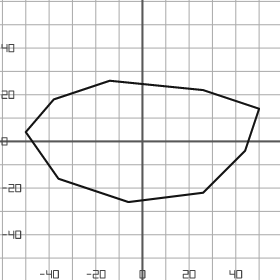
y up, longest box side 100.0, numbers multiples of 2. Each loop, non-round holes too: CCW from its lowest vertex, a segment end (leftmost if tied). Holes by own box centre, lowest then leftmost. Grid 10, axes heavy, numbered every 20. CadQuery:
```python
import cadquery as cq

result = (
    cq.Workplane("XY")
    .moveTo(-6.0, -26.0)
    .lineTo(26.0, -22.0)
    .lineTo(44.0, -4.0)
    .lineTo(50.0, 14.0)
    .lineTo(26.0, 22.0)
    .lineTo(-14.0, 26.0)
    .lineTo(-38.0, 18.0)
    .lineTo(-50.0, 4.0)
    .lineTo(-36.0, -16.0)
    .close()
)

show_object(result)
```